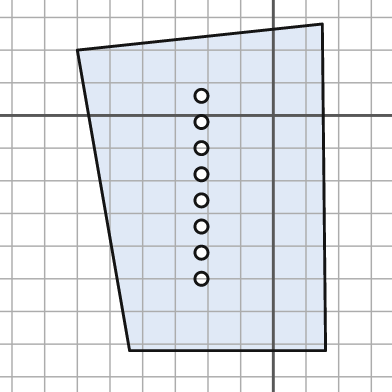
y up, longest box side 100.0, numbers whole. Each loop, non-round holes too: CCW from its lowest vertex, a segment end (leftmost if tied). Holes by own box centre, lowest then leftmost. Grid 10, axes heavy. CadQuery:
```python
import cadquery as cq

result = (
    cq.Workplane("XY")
    .moveTo(-44.0, -72.0)
    .lineTo(16.0, -72.0)
    .lineTo(15.0, 28.0)
    .lineTo(-60.0, 20.0)
    .close()
    .moveTo(-22.0, -50.0)
    .circle(2.0)
    .moveTo(-22.0, -42.0)
    .circle(2.0)
    .moveTo(-22.0, -34.0)
    .circle(2.0)
    .moveTo(-22.0, -26.0)
    .circle(2.0)
    .moveTo(-22.0, -18.0)
    .circle(2.0)
    .moveTo(-22.0, -10.0)
    .circle(2.0)
    .moveTo(-22.0, -2.0)
    .circle(2.0)
    .moveTo(-22.0, 6.0)
    .circle(2.0)
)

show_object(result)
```